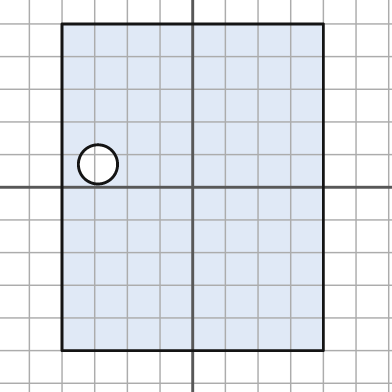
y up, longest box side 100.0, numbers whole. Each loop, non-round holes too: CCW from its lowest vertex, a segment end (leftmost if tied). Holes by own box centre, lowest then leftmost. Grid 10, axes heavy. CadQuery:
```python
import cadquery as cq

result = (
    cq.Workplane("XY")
    .moveTo(-40.0, -50.0)
    .lineTo(40.0, -50.0)
    .lineTo(40.0, 50.0)
    .lineTo(-40.0, 50.0)
    .close()
    .moveTo(-29.0, 7.0)
    .circle(6.0)
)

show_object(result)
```